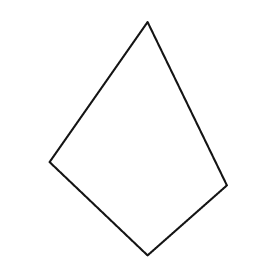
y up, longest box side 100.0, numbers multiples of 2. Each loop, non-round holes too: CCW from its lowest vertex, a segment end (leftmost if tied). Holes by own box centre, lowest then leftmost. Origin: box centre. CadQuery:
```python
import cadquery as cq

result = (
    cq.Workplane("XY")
    .moveTo(4.0, -50.0)
    .lineTo(38.0, -20.0)
    .lineTo(4.0, 50.0)
    .lineTo(-38.0, -10.0)
    .close()
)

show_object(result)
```